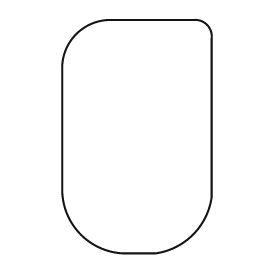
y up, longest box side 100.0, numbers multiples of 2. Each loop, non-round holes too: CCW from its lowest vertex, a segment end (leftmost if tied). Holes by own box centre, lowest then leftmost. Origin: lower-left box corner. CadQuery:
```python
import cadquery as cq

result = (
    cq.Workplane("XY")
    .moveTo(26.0, 0.0)
    .lineTo(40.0, 0.0)
    .threePointArc((56.0, 8.0), (64.0, 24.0))
    .lineTo(64.0, 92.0)
    .threePointArc((62.0, 98.0), (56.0, 100.0))
    .lineTo(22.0, 100.0)
    .threePointArc((6.0, 94.0), (0.0, 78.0))
    .lineTo(0.0, 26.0)
    .threePointArc((8.0, 8.0), (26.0, 0.0))
    .close()
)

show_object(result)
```